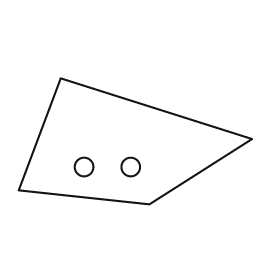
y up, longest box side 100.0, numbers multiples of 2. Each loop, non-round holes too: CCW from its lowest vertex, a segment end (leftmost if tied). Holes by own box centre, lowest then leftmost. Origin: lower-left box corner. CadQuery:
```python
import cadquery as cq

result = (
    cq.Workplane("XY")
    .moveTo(56.0, 0.0)
    .lineTo(100.0, 28.0)
    .lineTo(18.0, 54.0)
    .lineTo(0.0, 6.0)
    .close()
    .moveTo(28.0, 16.0)
    .circle(4.0)
    .moveTo(48.0, 16.0)
    .circle(4.0)
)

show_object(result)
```